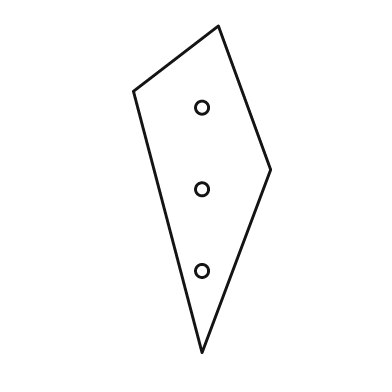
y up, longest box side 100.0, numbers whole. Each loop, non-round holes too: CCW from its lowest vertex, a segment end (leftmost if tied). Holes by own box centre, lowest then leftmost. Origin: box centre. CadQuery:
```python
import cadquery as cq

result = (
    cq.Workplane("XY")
    .moveTo(0.0, -50.0)
    .lineTo(21.0, 6.0)
    .lineTo(5.0, 50.0)
    .lineTo(-21.0, 30.0)
    .close()
    .moveTo(0.0, -25.0)
    .circle(2.0)
    .moveTo(0.0, 0.0)
    .circle(2.0)
    .moveTo(0.0, 25.0)
    .circle(2.0)
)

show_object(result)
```